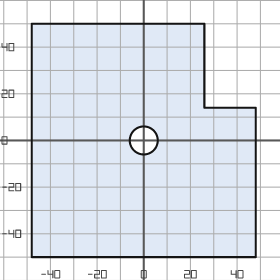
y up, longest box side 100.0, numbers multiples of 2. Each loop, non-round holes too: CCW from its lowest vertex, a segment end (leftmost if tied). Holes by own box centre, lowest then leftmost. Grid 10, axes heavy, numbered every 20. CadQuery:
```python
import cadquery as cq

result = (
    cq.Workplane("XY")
    .moveTo(-48.0, -50.0)
    .lineTo(48.0, -50.0)
    .lineTo(48.0, 14.0)
    .lineTo(26.0, 14.0)
    .lineTo(26.0, 50.0)
    .lineTo(-48.0, 50.0)
    .close()
    .moveTo(0.0, 0.0)
    .circle(6.0)
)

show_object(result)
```